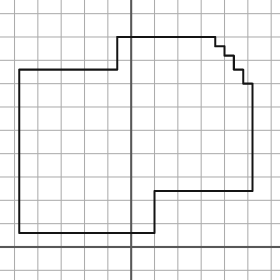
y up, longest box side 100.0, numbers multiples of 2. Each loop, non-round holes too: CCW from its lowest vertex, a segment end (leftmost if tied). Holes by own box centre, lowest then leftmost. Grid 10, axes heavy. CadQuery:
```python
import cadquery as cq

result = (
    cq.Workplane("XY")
    .moveTo(-48.0, 6.0)
    .lineTo(10.0, 6.0)
    .lineTo(10.0, 24.0)
    .lineTo(52.0, 24.0)
    .lineTo(52.0, 70.0)
    .lineTo(48.0, 70.0)
    .lineTo(48.0, 76.0)
    .lineTo(44.0, 76.0)
    .lineTo(44.0, 82.0)
    .lineTo(40.0, 82.0)
    .lineTo(40.0, 86.0)
    .lineTo(36.0, 86.0)
    .lineTo(36.0, 90.0)
    .lineTo(-6.0, 90.0)
    .lineTo(-6.0, 76.0)
    .lineTo(-48.0, 76.0)
    .close()
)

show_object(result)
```